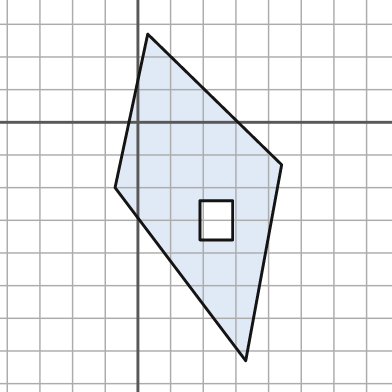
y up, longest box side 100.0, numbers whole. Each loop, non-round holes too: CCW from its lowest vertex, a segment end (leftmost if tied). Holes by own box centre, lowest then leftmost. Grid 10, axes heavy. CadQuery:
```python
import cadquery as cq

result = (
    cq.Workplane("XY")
    .moveTo(33.0, -73.0)
    .lineTo(44.0, -13.0)
    .lineTo(3.0, 27.0)
    .lineTo(-7.0, -20.0)
    .close()
    .moveTo(19.0, -36.0)
    .lineTo(29.0, -36.0)
    .lineTo(29.0, -24.0)
    .lineTo(19.0, -24.0)
    .close()
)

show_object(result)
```